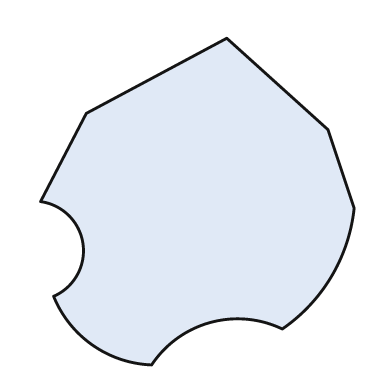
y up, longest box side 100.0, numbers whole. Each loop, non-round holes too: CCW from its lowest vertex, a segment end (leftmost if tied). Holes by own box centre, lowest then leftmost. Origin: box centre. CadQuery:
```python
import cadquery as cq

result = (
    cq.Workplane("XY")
    .moveTo(-14.0, -50.0)
    .threePointArc((4.0, -37.0), (26.0, -39.0))
    .threePointArc((41.0, -23.0), (48.0, -2.0))
    .lineTo(40.0, 22.0)
    .lineTo(9.0, 50.0)
    .lineTo(-34.0, 27.0)
    .lineTo(-48.0, 0.0)
    .threePointArc((-35.0, -13.0), (-44.0, -29.0))
    .threePointArc((-32.0, -44.0), (-14.0, -50.0))
    .close()
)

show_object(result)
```